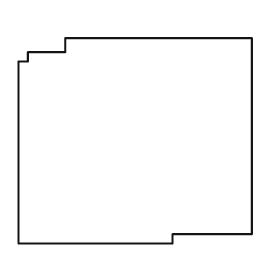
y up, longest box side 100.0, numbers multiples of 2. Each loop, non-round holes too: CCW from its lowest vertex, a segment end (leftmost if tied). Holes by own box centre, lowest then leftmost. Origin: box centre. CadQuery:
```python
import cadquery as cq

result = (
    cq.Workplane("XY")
    .moveTo(-50.0, -44.0)
    .lineTo(16.0, -44.0)
    .lineTo(16.0, -40.0)
    .lineTo(50.0, -40.0)
    .lineTo(50.0, 44.0)
    .lineTo(-30.0, 44.0)
    .lineTo(-30.0, 38.0)
    .lineTo(-46.0, 38.0)
    .lineTo(-46.0, 34.0)
    .lineTo(-50.0, 34.0)
    .close()
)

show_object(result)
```